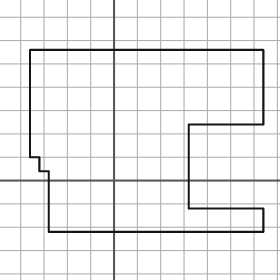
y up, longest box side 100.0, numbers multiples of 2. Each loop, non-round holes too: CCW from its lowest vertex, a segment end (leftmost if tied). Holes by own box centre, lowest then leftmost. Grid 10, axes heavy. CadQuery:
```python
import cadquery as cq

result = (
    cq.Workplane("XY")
    .moveTo(-28.0, -22.0)
    .lineTo(64.0, -22.0)
    .lineTo(64.0, -12.0)
    .lineTo(32.0, -12.0)
    .lineTo(32.0, 24.0)
    .lineTo(64.0, 24.0)
    .lineTo(64.0, 56.0)
    .lineTo(-36.0, 56.0)
    .lineTo(-36.0, 10.0)
    .lineTo(-32.0, 10.0)
    .lineTo(-32.0, 4.0)
    .lineTo(-28.0, 4.0)
    .close()
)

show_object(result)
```